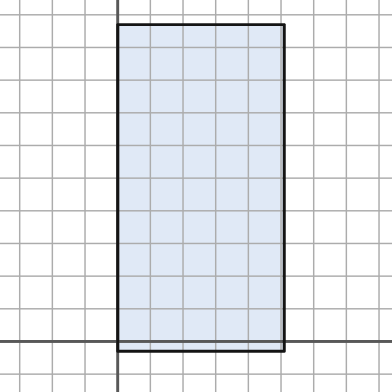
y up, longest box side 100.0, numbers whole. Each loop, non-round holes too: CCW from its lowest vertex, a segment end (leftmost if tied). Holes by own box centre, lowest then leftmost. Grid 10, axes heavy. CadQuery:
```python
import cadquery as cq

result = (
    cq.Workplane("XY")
    .moveTo(0.0, -3.0)
    .lineTo(51.0, -3.0)
    .lineTo(51.0, 97.0)
    .lineTo(0.0, 97.0)
    .close()
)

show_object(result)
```